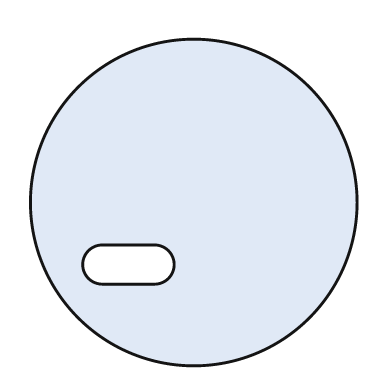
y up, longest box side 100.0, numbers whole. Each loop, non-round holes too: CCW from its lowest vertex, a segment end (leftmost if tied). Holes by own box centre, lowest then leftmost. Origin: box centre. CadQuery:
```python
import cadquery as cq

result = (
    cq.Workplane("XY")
    .moveTo(0.0, 0.0)
    .circle(50.0)
    .moveTo(-28.0, -25.0)
    .lineTo(-12.0, -25.0)
    .threePointArc((-6.0, -19.0), (-12.0, -13.0))
    .lineTo(-28.0, -13.0)
    .threePointArc((-34.0, -19.0), (-28.0, -25.0))
    .close()
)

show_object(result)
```